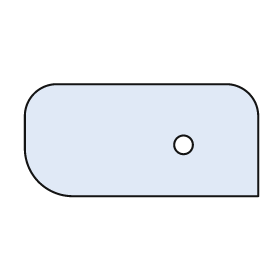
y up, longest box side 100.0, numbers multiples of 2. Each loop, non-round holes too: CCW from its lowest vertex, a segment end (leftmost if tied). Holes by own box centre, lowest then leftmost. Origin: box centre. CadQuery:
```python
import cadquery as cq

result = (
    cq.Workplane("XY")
    .moveTo(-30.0, -24.0)
    .lineTo(50.0, -24.0)
    .lineTo(50.0, 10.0)
    .threePointArc((46.0, 20.0), (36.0, 24.0))
    .lineTo(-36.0, 24.0)
    .threePointArc((-46.0, 20.0), (-50.0, 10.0))
    .lineTo(-50.0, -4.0)
    .threePointArc((-44.0, -18.0), (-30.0, -24.0))
    .close()
    .moveTo(18.0, -2.0)
    .circle(4.0)
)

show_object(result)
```